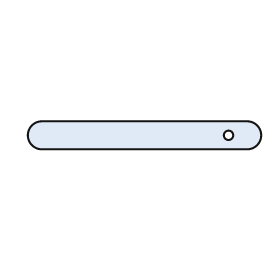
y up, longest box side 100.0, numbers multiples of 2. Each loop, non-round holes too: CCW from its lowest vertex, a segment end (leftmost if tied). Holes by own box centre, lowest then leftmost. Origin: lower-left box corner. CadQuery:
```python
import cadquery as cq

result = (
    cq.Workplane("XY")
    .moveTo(6.0, 0.0)
    .lineTo(94.0, 0.0)
    .threePointArc((100.0, 6.0), (94.0, 12.0))
    .lineTo(6.0, 12.0)
    .threePointArc((0.0, 6.0), (6.0, 0.0))
    .close()
    .moveTo(86.0, 6.0)
    .circle(2.0)
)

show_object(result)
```